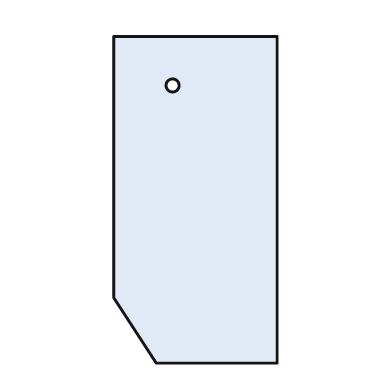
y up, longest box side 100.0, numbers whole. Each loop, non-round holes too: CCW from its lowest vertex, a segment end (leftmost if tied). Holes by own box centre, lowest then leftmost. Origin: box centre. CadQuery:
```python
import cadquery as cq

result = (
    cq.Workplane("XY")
    .moveTo(-12.0, -50.0)
    .lineTo(25.0, -50.0)
    .lineTo(25.0, 50.0)
    .lineTo(-25.0, 50.0)
    .lineTo(-25.0, -30.0)
    .close()
    .moveTo(-7.0, 35.0)
    .circle(2.0)
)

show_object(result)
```